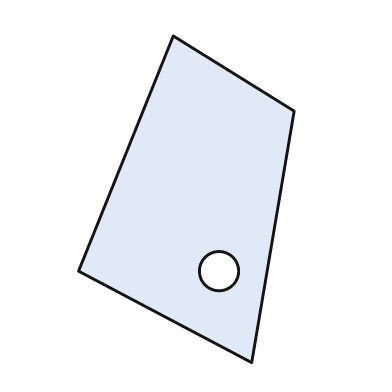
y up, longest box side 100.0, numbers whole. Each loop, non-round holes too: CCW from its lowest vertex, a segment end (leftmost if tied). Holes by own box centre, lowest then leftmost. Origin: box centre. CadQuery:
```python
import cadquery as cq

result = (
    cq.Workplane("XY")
    .moveTo(20.0, -50.0)
    .lineTo(33.0, 27.0)
    .lineTo(-4.0, 50.0)
    .lineTo(-33.0, -22.0)
    .close()
    .moveTo(10.0, -22.0)
    .circle(6.0)
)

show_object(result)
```